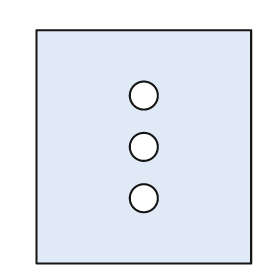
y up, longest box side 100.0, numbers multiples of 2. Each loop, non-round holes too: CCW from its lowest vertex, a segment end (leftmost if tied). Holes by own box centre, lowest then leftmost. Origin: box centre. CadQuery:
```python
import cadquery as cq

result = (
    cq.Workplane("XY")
    .moveTo(-46.0, -50.0)
    .lineTo(46.0, -50.0)
    .lineTo(46.0, 50.0)
    .lineTo(-46.0, 50.0)
    .close()
    .moveTo(0.0, -22.0)
    .circle(6.0)
    .moveTo(0.0, 0.0)
    .circle(6.0)
    .moveTo(0.0, 22.0)
    .circle(6.0)
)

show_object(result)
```